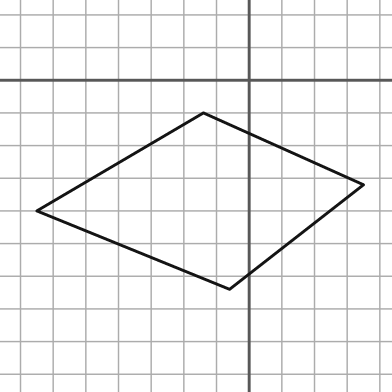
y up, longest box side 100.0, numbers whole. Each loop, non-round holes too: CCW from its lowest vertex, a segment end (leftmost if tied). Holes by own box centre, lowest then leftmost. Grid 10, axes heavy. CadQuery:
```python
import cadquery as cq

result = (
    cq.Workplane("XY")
    .moveTo(-6.0, -64.0)
    .lineTo(35.0, -32.0)
    .lineTo(-14.0, -10.0)
    .lineTo(-65.0, -40.0)
    .close()
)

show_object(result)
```